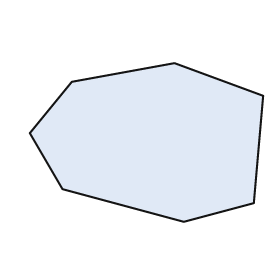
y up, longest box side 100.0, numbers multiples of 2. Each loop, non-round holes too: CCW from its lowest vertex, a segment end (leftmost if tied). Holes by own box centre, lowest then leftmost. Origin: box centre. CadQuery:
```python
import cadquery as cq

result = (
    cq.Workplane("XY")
    .moveTo(16.0, -34.0)
    .lineTo(46.0, -26.0)
    .lineTo(50.0, 20.0)
    .lineTo(12.0, 34.0)
    .lineTo(-32.0, 26.0)
    .lineTo(-50.0, 4.0)
    .lineTo(-36.0, -20.0)
    .close()
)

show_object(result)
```